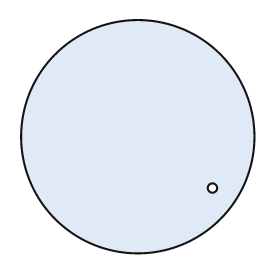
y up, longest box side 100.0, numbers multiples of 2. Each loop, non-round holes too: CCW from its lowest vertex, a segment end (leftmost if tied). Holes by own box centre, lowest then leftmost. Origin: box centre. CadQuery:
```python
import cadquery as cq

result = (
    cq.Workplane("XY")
    .moveTo(0.0, 0.0)
    .circle(50.0)
    .moveTo(32.0, -22.0)
    .circle(2.0)
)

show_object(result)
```